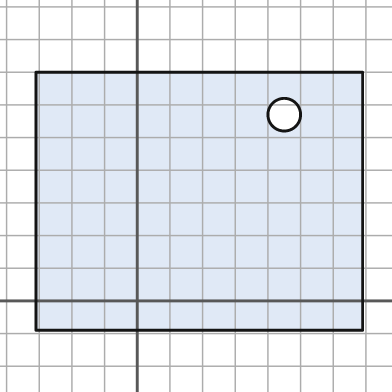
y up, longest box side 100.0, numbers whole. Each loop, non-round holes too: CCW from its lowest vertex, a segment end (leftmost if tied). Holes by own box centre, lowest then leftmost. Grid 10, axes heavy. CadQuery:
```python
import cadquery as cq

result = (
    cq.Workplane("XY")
    .moveTo(-31.0, -9.0)
    .lineTo(69.0, -9.0)
    .lineTo(69.0, 70.0)
    .lineTo(-31.0, 70.0)
    .close()
    .moveTo(45.0, 57.0)
    .circle(5.0)
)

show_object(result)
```